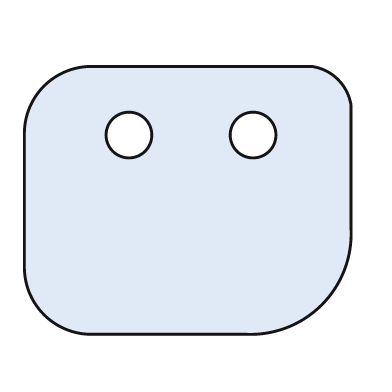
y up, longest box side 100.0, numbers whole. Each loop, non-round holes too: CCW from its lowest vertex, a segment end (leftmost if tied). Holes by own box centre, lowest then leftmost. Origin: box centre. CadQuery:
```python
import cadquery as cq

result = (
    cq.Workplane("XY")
    .moveTo(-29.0, -41.0)
    .lineTo(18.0, -41.0)
    .threePointArc((41.0, -32.0), (50.0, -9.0))
    .lineTo(50.0, 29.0)
    .threePointArc((46.0, 37.0), (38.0, 41.0))
    .lineTo(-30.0, 41.0)
    .threePointArc((-44.0, 35.0), (-50.0, 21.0))
    .lineTo(-50.0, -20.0)
    .threePointArc((-44.0, -35.0), (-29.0, -41.0))
    .close()
    .moveTo(-18.0, 20.0)
    .circle(7.0)
    .moveTo(20.0, 20.0)
    .circle(7.0)
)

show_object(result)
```